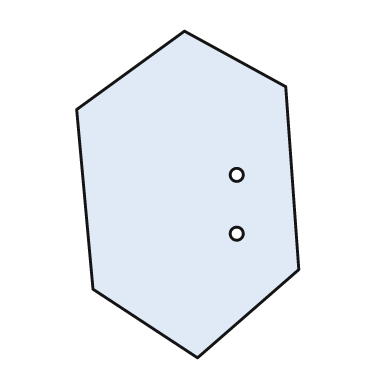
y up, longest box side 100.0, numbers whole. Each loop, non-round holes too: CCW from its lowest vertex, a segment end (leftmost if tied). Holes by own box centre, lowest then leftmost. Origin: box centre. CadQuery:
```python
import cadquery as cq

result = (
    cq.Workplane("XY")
    .moveTo(3.0, -50.0)
    .lineTo(34.0, -23.0)
    .lineTo(30.0, 33.0)
    .lineTo(-1.0, 50.0)
    .lineTo(-34.0, 26.0)
    .lineTo(-29.0, -29.0)
    .close()
    .moveTo(15.0, -12.0)
    .circle(2.0)
    .moveTo(15.0, 6.0)
    .circle(2.0)
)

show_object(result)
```